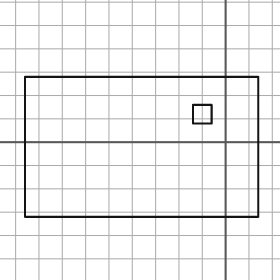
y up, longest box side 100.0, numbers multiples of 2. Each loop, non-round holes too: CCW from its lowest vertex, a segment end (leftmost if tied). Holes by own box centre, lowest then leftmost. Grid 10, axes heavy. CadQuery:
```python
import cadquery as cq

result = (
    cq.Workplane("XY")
    .moveTo(-86.0, -32.0)
    .lineTo(14.0, -32.0)
    .lineTo(14.0, 28.0)
    .lineTo(-86.0, 28.0)
    .close()
    .moveTo(-14.0, 8.0)
    .lineTo(-6.0, 8.0)
    .lineTo(-6.0, 16.0)
    .lineTo(-14.0, 16.0)
    .close()
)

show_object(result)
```